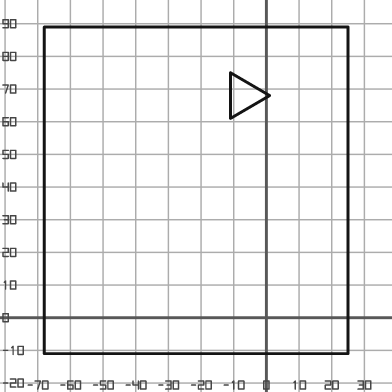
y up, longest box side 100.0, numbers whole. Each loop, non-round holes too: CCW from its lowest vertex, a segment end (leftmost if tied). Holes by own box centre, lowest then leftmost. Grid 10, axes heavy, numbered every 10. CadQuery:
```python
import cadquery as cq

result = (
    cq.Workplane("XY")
    .moveTo(-68.0, -11.0)
    .lineTo(25.0, -11.0)
    .lineTo(25.0, 89.0)
    .lineTo(-68.0, 89.0)
    .close()
    .moveTo(-11.0, 61.0)
    .lineTo(1.0, 68.0)
    .lineTo(-11.0, 75.0)
    .close()
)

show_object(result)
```